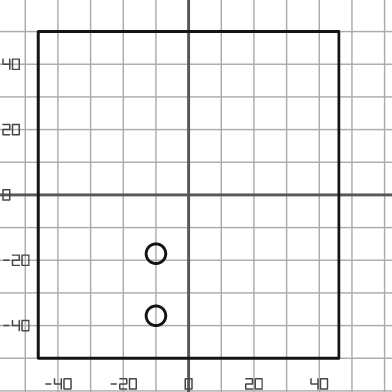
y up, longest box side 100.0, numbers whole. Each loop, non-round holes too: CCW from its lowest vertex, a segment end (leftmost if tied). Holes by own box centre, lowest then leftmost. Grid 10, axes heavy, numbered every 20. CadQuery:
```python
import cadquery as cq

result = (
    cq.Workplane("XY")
    .moveTo(-46.0, -50.0)
    .lineTo(46.0, -50.0)
    .lineTo(46.0, 50.0)
    .lineTo(-46.0, 50.0)
    .close()
    .moveTo(-10.0, -37.0)
    .circle(3.0)
    .moveTo(-10.0, -18.0)
    .circle(3.0)
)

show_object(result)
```